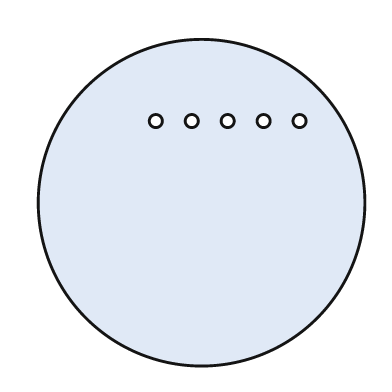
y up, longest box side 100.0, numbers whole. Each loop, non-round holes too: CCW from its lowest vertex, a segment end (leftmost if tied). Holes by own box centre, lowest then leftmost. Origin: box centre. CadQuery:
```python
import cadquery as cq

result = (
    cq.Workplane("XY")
    .moveTo(0.0, 0.0)
    .circle(50.0)
    .moveTo(-14.0, 25.0)
    .circle(2.0)
    .moveTo(-3.0, 25.0)
    .circle(2.0)
    .moveTo(8.0, 25.0)
    .circle(2.0)
    .moveTo(19.0, 25.0)
    .circle(2.0)
    .moveTo(30.0, 25.0)
    .circle(2.0)
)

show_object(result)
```